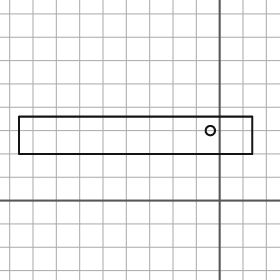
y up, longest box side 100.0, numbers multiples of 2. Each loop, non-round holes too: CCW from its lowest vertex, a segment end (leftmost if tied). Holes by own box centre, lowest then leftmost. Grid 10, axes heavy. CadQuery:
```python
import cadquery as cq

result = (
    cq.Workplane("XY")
    .moveTo(-86.0, 20.0)
    .lineTo(14.0, 20.0)
    .lineTo(14.0, 36.0)
    .lineTo(-86.0, 36.0)
    .close()
    .moveTo(-4.0, 30.0)
    .circle(2.0)
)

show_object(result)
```